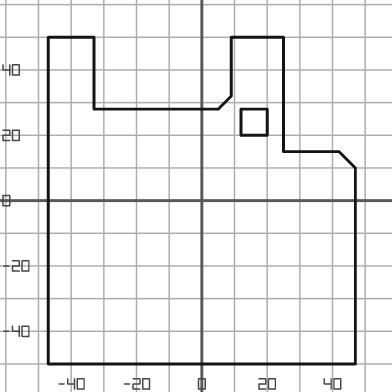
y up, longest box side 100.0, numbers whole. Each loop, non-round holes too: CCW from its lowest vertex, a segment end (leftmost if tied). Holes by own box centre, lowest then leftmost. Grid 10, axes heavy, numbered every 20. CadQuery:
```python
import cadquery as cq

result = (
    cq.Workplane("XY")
    .moveTo(-47.0, -50.0)
    .lineTo(47.0, -50.0)
    .lineTo(47.0, 10.0)
    .lineTo(42.0, 15.0)
    .lineTo(25.0, 15.0)
    .lineTo(25.0, 50.0)
    .lineTo(9.0, 50.0)
    .lineTo(9.0, 32.0)
    .lineTo(5.0, 28.0)
    .lineTo(-33.0, 28.0)
    .lineTo(-33.0, 50.0)
    .lineTo(-47.0, 50.0)
    .close()
    .moveTo(12.0, 20.0)
    .lineTo(20.0, 20.0)
    .lineTo(20.0, 28.0)
    .lineTo(12.0, 28.0)
    .close()
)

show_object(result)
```